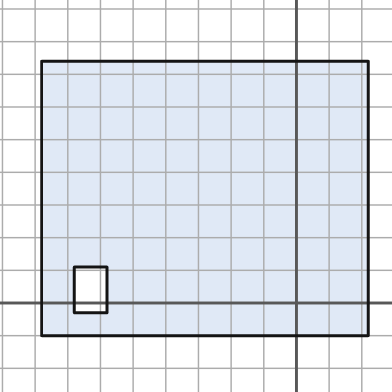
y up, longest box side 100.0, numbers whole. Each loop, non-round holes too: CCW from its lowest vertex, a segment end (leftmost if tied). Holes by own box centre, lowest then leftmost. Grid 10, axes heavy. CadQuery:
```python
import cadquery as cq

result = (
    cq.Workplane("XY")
    .moveTo(-78.0, -10.0)
    .lineTo(22.0, -10.0)
    .lineTo(22.0, 74.0)
    .lineTo(-78.0, 74.0)
    .close()
    .moveTo(-68.0, -3.0)
    .lineTo(-58.0, -3.0)
    .lineTo(-58.0, 11.0)
    .lineTo(-68.0, 11.0)
    .close()
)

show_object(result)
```